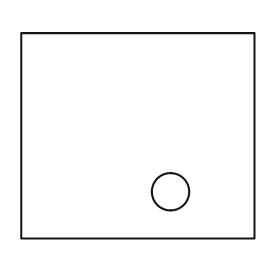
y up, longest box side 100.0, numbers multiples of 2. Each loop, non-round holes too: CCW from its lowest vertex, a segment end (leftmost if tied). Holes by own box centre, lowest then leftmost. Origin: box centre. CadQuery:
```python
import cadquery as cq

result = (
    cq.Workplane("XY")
    .moveTo(-50.0, -44.0)
    .lineTo(50.0, -44.0)
    .lineTo(50.0, 44.0)
    .lineTo(-50.0, 44.0)
    .close()
    .moveTo(14.0, -24.0)
    .circle(8.0)
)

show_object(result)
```